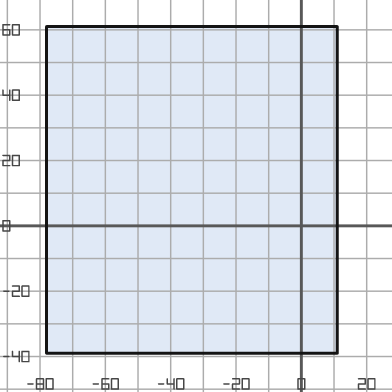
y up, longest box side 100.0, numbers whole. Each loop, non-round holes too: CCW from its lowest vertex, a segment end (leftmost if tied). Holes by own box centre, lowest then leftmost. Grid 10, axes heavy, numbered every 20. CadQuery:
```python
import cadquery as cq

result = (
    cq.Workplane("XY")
    .moveTo(-78.0, -39.0)
    .lineTo(11.0, -39.0)
    .lineTo(11.0, 61.0)
    .lineTo(-78.0, 61.0)
    .close()
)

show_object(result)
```